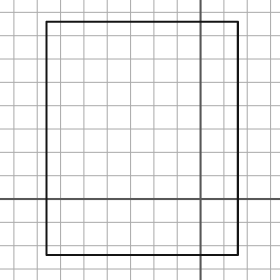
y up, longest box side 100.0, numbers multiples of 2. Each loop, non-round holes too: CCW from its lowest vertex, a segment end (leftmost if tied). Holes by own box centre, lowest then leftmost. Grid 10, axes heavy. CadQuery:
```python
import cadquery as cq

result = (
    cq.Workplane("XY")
    .moveTo(-66.0, -24.0)
    .lineTo(16.0, -24.0)
    .lineTo(16.0, 76.0)
    .lineTo(-66.0, 76.0)
    .close()
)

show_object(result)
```